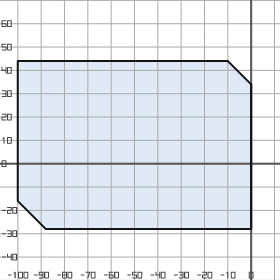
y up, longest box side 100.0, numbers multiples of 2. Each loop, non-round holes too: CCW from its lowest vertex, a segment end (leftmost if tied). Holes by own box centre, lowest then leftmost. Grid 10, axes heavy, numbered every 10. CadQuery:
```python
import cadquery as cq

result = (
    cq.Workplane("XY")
    .moveTo(-88.0, -28.0)
    .lineTo(0.0, -28.0)
    .lineTo(0.0, 34.0)
    .lineTo(-10.0, 44.0)
    .lineTo(-100.0, 44.0)
    .lineTo(-100.0, -16.0)
    .close()
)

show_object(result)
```